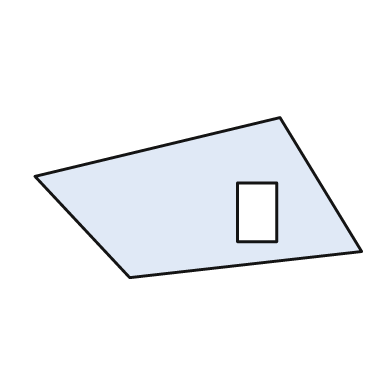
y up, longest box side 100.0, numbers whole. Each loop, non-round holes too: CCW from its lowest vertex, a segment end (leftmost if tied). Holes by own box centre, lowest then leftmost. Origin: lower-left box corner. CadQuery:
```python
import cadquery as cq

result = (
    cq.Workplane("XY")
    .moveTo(29.0, 0.0)
    .lineTo(100.0, 8.0)
    .lineTo(75.0, 49.0)
    .lineTo(0.0, 31.0)
    .close()
    .moveTo(62.0, 11.0)
    .lineTo(74.0, 11.0)
    .lineTo(74.0, 29.0)
    .lineTo(62.0, 29.0)
    .close()
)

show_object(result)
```